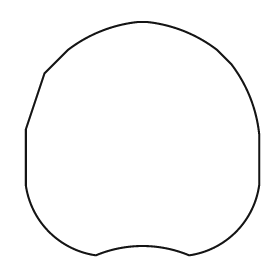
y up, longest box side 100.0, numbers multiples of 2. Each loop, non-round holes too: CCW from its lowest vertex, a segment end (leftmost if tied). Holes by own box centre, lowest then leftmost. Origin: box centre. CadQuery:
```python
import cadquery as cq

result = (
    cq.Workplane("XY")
    .moveTo(-20.0, -50.0)
    .threePointArc((0.0, -46.0), (20.0, -50.0))
    .threePointArc((40.0, -40.0), (50.0, -20.0))
    .lineTo(50.0, 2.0)
    .threePointArc((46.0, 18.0), (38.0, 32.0))
    .lineTo(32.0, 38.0)
    .threePointArc((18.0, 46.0), (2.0, 50.0))
    .lineTo(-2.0, 50.0)
    .threePointArc((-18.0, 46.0), (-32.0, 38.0))
    .lineTo(-42.0, 28.0)
    .lineTo(-50.0, 4.0)
    .lineTo(-50.0, -20.0)
    .threePointArc((-40.0, -40.0), (-20.0, -50.0))
    .close()
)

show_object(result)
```